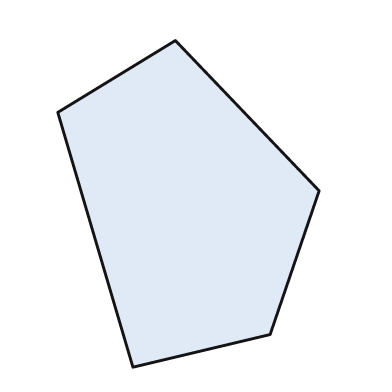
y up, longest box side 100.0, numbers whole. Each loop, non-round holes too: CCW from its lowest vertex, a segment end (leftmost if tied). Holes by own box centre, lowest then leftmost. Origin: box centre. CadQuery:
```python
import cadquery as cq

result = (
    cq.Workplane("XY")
    .moveTo(-17.0, -50.0)
    .lineTo(25.0, -40.0)
    .lineTo(40.0, 4.0)
    .lineTo(-4.0, 50.0)
    .lineTo(-40.0, 28.0)
    .close()
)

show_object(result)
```